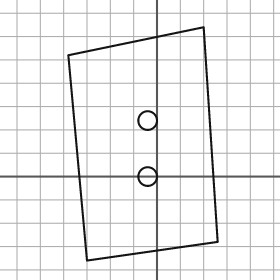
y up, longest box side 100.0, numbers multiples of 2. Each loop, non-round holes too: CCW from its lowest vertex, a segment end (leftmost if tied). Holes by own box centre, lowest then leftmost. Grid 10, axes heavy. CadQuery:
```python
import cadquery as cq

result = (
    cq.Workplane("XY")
    .moveTo(-30.0, -36.0)
    .lineTo(26.0, -28.0)
    .lineTo(20.0, 64.0)
    .lineTo(-38.0, 52.0)
    .close()
    .moveTo(-4.0, 0.0)
    .circle(4.0)
    .moveTo(-4.0, 24.0)
    .circle(4.0)
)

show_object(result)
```